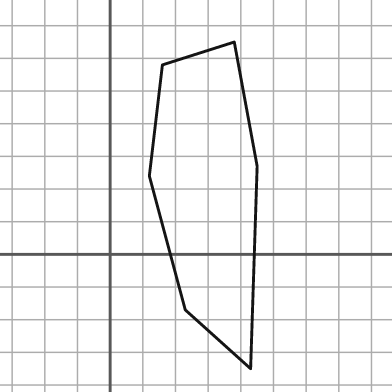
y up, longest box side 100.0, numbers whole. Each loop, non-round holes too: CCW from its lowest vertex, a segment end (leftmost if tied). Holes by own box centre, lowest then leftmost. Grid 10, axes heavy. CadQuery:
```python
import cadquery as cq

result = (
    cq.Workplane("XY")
    .moveTo(43.0, -35.0)
    .lineTo(45.0, 27.0)
    .lineTo(38.0, 65.0)
    .lineTo(16.0, 58.0)
    .lineTo(12.0, 24.0)
    .lineTo(23.0, -17.0)
    .close()
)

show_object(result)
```